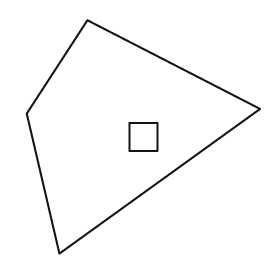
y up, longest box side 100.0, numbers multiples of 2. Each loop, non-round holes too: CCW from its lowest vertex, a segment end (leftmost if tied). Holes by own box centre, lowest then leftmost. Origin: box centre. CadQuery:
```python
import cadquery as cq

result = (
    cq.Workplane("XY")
    .moveTo(-36.0, -50.0)
    .lineTo(50.0, 12.0)
    .lineTo(-24.0, 50.0)
    .lineTo(-50.0, 10.0)
    .close()
    .moveTo(-6.0, -6.0)
    .lineTo(6.0, -6.0)
    .lineTo(6.0, 6.0)
    .lineTo(-6.0, 6.0)
    .close()
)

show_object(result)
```